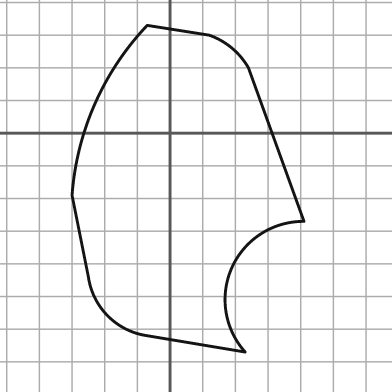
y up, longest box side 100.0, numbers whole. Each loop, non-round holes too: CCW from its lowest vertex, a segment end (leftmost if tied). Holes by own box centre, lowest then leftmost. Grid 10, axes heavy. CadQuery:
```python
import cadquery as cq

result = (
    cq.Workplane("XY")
    .moveTo(23.0, -67.0)
    .threePointArc((19.0, -41.0), (41.0, -27.0))
    .lineTo(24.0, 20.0)
    .threePointArc((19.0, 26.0), (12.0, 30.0))
    .lineTo(-7.0, 33.0)
    .threePointArc((-23.0, 9.0), (-30.0, -19.0))
    .lineTo(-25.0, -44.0)
    .threePointArc((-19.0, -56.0), (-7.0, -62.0))
    .close()
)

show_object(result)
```